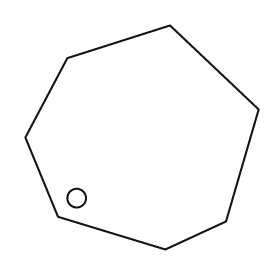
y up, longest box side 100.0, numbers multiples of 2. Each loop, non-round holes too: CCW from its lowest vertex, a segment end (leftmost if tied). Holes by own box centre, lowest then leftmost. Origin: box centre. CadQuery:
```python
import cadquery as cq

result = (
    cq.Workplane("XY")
    .moveTo(10.0, -48.0)
    .lineTo(36.0, -36.0)
    .lineTo(50.0, 12.0)
    .lineTo(12.0, 48.0)
    .lineTo(-32.0, 34.0)
    .lineTo(-50.0, 0.0)
    .lineTo(-36.0, -34.0)
    .close()
    .moveTo(-28.0, -26.0)
    .circle(4.0)
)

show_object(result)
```